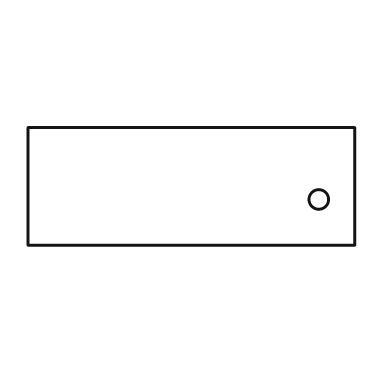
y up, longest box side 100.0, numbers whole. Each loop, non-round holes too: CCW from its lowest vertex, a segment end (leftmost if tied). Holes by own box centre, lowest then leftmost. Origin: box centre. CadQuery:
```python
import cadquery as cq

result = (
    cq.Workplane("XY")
    .moveTo(-50.0, -18.0)
    .lineTo(50.0, -18.0)
    .lineTo(50.0, 18.0)
    .lineTo(-50.0, 18.0)
    .close()
    .moveTo(39.0, -4.0)
    .circle(3.0)
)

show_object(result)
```